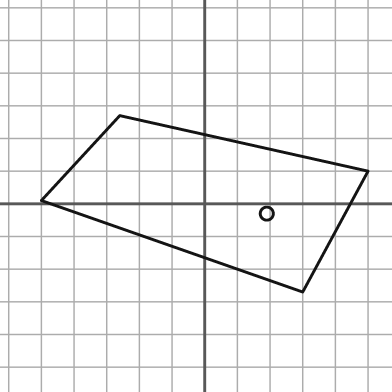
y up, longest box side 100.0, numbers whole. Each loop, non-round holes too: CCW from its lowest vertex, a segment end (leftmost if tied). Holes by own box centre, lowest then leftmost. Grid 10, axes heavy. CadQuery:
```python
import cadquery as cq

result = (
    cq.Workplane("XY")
    .moveTo(30.0, -27.0)
    .lineTo(50.0, 10.0)
    .lineTo(-26.0, 27.0)
    .lineTo(-50.0, 1.0)
    .close()
    .moveTo(19.0, -3.0)
    .circle(2.0)
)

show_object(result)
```